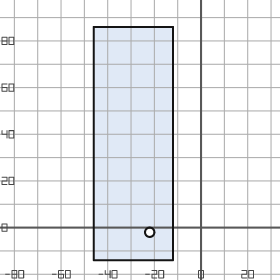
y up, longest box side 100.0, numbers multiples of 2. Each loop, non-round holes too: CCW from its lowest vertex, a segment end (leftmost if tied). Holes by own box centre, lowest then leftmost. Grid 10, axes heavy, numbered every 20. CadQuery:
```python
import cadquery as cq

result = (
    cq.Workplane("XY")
    .moveTo(-46.0, -14.0)
    .lineTo(-12.0, -14.0)
    .lineTo(-12.0, 86.0)
    .lineTo(-46.0, 86.0)
    .close()
    .moveTo(-22.0, -2.0)
    .circle(2.0)
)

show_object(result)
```